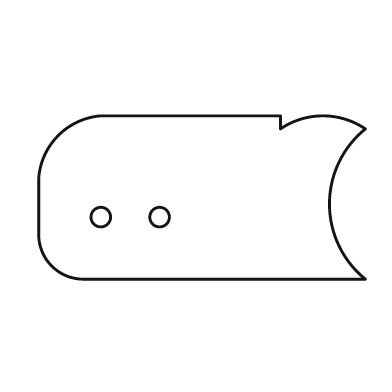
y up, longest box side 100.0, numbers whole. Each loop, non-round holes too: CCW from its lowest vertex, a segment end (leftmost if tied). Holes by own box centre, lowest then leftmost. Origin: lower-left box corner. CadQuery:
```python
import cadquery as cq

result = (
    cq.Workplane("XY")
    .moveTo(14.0, 0.0)
    .lineTo(100.0, 0.0)
    .threePointArc((89.0, 23.0), (100.0, 46.0))
    .threePointArc((87.0, 50.0), (74.0, 46.0))
    .lineTo(74.0, 50.0)
    .lineTo(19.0, 50.0)
    .threePointArc((6.0, 44.0), (0.0, 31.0))
    .lineTo(0.0, 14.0)
    .threePointArc((4.0, 4.0), (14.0, 0.0))
    .close()
    .moveTo(19.0, 19.0)
    .circle(3.0)
    .moveTo(37.0, 19.0)
    .circle(3.0)
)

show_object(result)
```